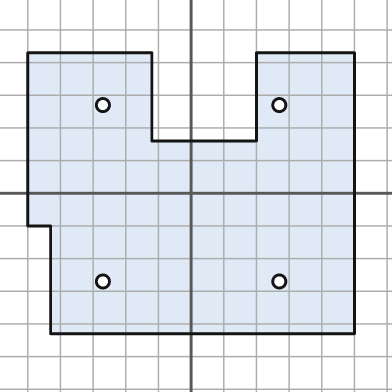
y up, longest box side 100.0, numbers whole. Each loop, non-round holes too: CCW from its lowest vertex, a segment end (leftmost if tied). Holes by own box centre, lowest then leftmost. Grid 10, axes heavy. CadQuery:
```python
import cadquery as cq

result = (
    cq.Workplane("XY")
    .moveTo(-43.0, -43.0)
    .lineTo(50.0, -43.0)
    .lineTo(50.0, 43.0)
    .lineTo(20.0, 43.0)
    .lineTo(20.0, 16.0)
    .lineTo(-12.0, 16.0)
    .lineTo(-12.0, 43.0)
    .lineTo(-50.0, 43.0)
    .lineTo(-50.0, -10.0)
    .lineTo(-43.0, -10.0)
    .close()
    .moveTo(-27.0, -27.0)
    .circle(2.0)
    .moveTo(27.0, -27.0)
    .circle(2.0)
    .moveTo(-27.0, 27.0)
    .circle(2.0)
    .moveTo(27.0, 27.0)
    .circle(2.0)
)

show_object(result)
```